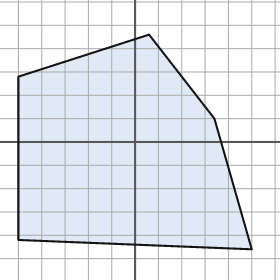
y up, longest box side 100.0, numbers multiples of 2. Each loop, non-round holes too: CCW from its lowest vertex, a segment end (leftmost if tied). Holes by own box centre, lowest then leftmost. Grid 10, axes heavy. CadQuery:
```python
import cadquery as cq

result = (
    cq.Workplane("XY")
    .moveTo(50.0, -46.0)
    .lineTo(34.0, 10.0)
    .lineTo(6.0, 46.0)
    .lineTo(-50.0, 28.0)
    .lineTo(-50.0, -42.0)
    .close()
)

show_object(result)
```